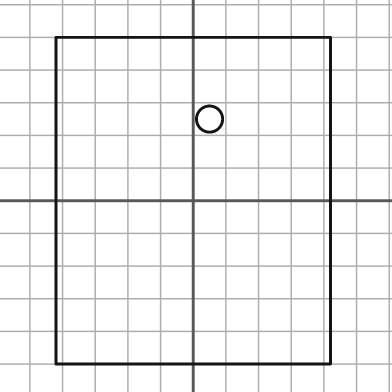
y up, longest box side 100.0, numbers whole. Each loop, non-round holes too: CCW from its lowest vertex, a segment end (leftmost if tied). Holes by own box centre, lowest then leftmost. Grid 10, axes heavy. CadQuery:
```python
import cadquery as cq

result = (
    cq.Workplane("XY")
    .moveTo(-42.0, -50.0)
    .lineTo(42.0, -50.0)
    .lineTo(42.0, 50.0)
    .lineTo(-42.0, 50.0)
    .close()
    .moveTo(5.0, 25.0)
    .circle(4.0)
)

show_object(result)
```